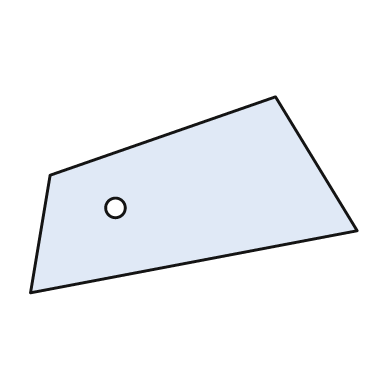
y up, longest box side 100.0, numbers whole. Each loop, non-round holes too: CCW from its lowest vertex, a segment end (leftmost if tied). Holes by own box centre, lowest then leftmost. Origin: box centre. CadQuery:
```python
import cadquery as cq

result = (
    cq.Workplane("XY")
    .moveTo(-50.0, -30.0)
    .lineTo(50.0, -11.0)
    .lineTo(25.0, 30.0)
    .lineTo(-44.0, 6.0)
    .close()
    .moveTo(-24.0, -4.0)
    .circle(3.0)
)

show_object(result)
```